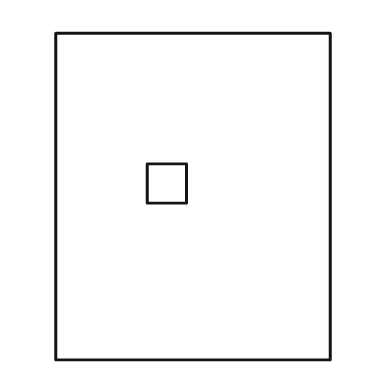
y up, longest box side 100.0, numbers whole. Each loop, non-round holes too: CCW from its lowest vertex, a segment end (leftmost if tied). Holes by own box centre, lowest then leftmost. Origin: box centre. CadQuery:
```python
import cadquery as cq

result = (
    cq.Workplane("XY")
    .moveTo(-42.0, -50.0)
    .lineTo(42.0, -50.0)
    .lineTo(42.0, 50.0)
    .lineTo(-42.0, 50.0)
    .close()
    .moveTo(-14.0, -2.0)
    .lineTo(-2.0, -2.0)
    .lineTo(-2.0, 10.0)
    .lineTo(-14.0, 10.0)
    .close()
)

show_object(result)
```